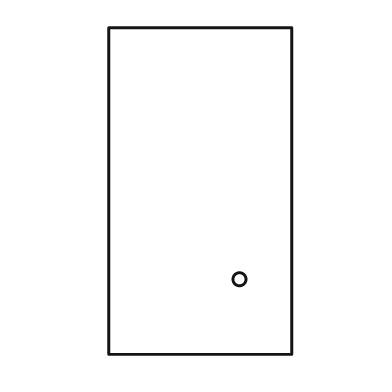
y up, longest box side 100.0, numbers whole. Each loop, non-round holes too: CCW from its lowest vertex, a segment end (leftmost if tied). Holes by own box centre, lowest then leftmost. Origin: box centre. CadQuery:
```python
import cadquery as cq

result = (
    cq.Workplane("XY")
    .moveTo(-28.0, -50.0)
    .lineTo(28.0, -50.0)
    .lineTo(28.0, 50.0)
    .lineTo(-28.0, 50.0)
    .close()
    .moveTo(12.0, -27.0)
    .circle(2.0)
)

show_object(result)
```